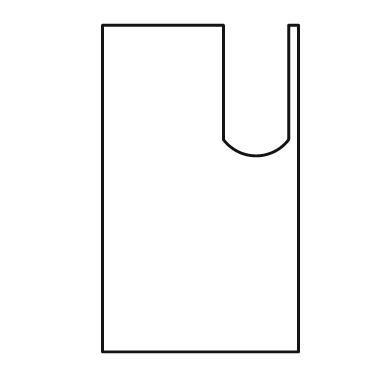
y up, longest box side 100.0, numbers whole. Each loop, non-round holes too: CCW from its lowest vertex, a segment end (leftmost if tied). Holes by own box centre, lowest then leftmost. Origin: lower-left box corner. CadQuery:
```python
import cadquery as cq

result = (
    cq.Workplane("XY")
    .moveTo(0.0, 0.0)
    .lineTo(60.0, 0.0)
    .lineTo(60.0, 100.0)
    .lineTo(57.0, 100.0)
    .lineTo(57.0, 65.0)
    .threePointArc((47.0, 60.0), (37.0, 65.0))
    .lineTo(37.0, 100.0)
    .lineTo(0.0, 100.0)
    .close()
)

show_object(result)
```